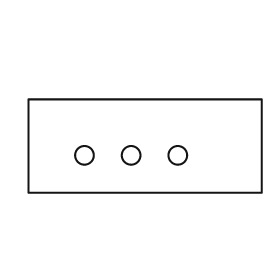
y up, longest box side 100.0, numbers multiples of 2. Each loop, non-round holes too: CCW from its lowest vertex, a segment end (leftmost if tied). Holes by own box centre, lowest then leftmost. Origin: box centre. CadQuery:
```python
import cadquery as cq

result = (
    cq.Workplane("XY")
    .moveTo(-50.0, -20.0)
    .lineTo(50.0, -20.0)
    .lineTo(50.0, 20.0)
    .lineTo(-50.0, 20.0)
    .close()
    .moveTo(-26.0, -4.0)
    .circle(4.0)
    .moveTo(-6.0, -4.0)
    .circle(4.0)
    .moveTo(14.0, -4.0)
    .circle(4.0)
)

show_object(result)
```